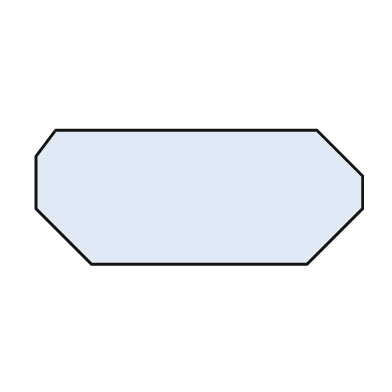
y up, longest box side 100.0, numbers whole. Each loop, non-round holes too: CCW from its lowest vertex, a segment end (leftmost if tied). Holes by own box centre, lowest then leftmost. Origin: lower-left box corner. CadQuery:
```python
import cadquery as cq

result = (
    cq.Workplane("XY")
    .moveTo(17.0, 0.0)
    .lineTo(83.0, 0.0)
    .lineTo(100.0, 17.0)
    .lineTo(100.0, 27.0)
    .lineTo(86.0, 41.0)
    .lineTo(6.0, 41.0)
    .lineTo(0.0, 33.0)
    .lineTo(0.0, 17.0)
    .close()
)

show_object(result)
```